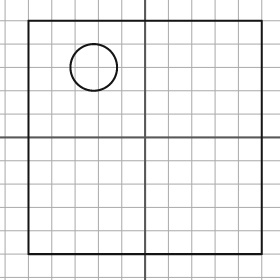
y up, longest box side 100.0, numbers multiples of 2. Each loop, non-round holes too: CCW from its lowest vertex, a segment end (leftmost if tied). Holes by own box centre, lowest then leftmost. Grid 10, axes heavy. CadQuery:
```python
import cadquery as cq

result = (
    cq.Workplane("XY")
    .moveTo(-50.0, -50.0)
    .lineTo(50.0, -50.0)
    .lineTo(50.0, 50.0)
    .lineTo(-50.0, 50.0)
    .close()
    .moveTo(-22.0, 30.0)
    .circle(10.0)
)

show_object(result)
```